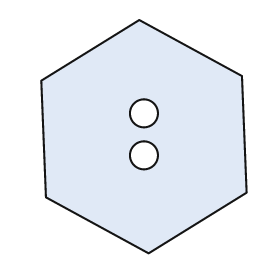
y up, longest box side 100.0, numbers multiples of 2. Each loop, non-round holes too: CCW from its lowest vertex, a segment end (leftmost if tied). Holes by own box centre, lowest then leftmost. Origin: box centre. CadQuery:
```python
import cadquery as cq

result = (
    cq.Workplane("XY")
    .moveTo(2.0, -50.0)
    .lineTo(44.0, -24.0)
    .lineTo(42.0, 26.0)
    .lineTo(-2.0, 50.0)
    .lineTo(-44.0, 24.0)
    .lineTo(-42.0, -26.0)
    .close()
    .moveTo(0.0, -8.0)
    .circle(6.0)
    .moveTo(0.0, 10.0)
    .circle(6.0)
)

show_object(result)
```